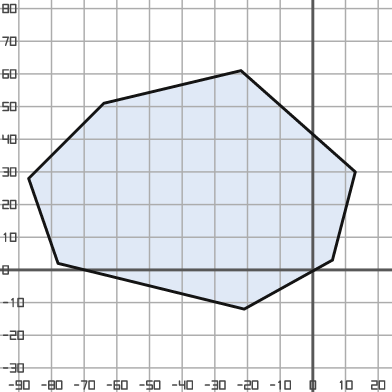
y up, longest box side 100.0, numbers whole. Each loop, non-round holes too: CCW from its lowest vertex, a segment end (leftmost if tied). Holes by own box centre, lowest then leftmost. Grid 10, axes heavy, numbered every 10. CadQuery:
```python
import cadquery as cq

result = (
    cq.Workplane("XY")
    .moveTo(-21.0, -12.0)
    .lineTo(6.0, 3.0)
    .lineTo(13.0, 30.0)
    .lineTo(-22.0, 61.0)
    .lineTo(-64.0, 51.0)
    .lineTo(-87.0, 28.0)
    .lineTo(-78.0, 2.0)
    .close()
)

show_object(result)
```